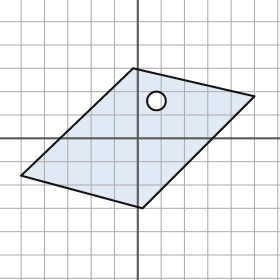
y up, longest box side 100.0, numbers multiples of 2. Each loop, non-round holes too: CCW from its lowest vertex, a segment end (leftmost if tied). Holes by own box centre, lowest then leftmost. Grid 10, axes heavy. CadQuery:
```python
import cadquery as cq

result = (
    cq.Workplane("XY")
    .moveTo(2.0, -30.0)
    .lineTo(50.0, 18.0)
    .lineTo(-2.0, 30.0)
    .lineTo(-50.0, -16.0)
    .close()
    .moveTo(8.0, 16.0)
    .circle(4.0)
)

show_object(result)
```